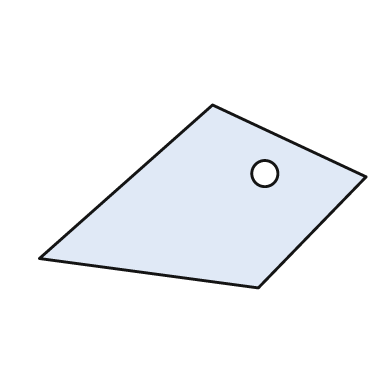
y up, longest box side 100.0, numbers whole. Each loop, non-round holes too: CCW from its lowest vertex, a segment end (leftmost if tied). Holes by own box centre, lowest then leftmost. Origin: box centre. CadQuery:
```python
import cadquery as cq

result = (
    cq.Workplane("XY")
    .moveTo(17.0, -28.0)
    .lineTo(50.0, 6.0)
    .lineTo(3.0, 28.0)
    .lineTo(-50.0, -19.0)
    .close()
    .moveTo(19.0, 7.0)
    .circle(4.0)
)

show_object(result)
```